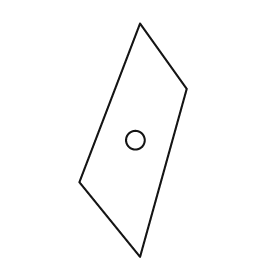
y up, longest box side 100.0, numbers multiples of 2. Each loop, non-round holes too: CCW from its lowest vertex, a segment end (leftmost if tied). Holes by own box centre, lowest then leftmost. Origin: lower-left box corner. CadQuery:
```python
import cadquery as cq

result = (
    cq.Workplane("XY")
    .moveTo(26.0, 0.0)
    .lineTo(46.0, 72.0)
    .lineTo(26.0, 100.0)
    .lineTo(0.0, 32.0)
    .close()
    .moveTo(24.0, 50.0)
    .circle(4.0)
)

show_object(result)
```